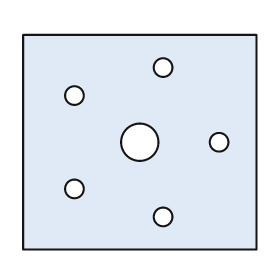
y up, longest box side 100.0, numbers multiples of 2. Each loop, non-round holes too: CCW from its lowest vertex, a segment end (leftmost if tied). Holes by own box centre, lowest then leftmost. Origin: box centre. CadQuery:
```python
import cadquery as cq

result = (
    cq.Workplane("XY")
    .moveTo(-50.0, -46.0)
    .lineTo(50.0, -46.0)
    .lineTo(50.0, 46.0)
    .lineTo(-50.0, 46.0)
    .close()
    .moveTo(10.0, -32.0)
    .circle(4.0)
    .moveTo(-28.0, -20.0)
    .circle(4.0)
    .moveTo(0.0, 0.0)
    .circle(8.0)
    .moveTo(34.0, 0.0)
    .circle(4.0)
    .moveTo(-28.0, 20.0)
    .circle(4.0)
    .moveTo(10.0, 32.0)
    .circle(4.0)
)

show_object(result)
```